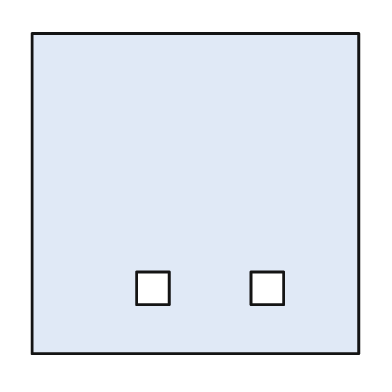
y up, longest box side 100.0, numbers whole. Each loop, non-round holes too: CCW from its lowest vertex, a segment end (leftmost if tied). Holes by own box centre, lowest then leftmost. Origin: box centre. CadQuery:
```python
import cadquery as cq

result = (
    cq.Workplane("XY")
    .moveTo(-50.0, -49.0)
    .lineTo(50.0, -49.0)
    .lineTo(50.0, 49.0)
    .lineTo(-50.0, 49.0)
    .close()
    .moveTo(-18.0, -34.0)
    .lineTo(-8.0, -34.0)
    .lineTo(-8.0, -24.0)
    .lineTo(-18.0, -24.0)
    .close()
    .moveTo(17.0, -34.0)
    .lineTo(27.0, -34.0)
    .lineTo(27.0, -24.0)
    .lineTo(17.0, -24.0)
    .close()
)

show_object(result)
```